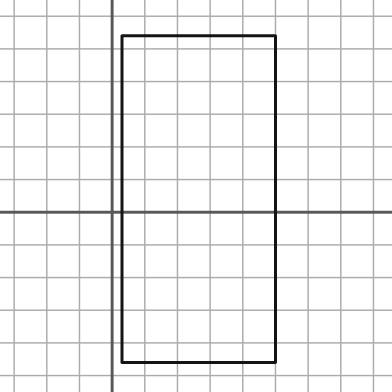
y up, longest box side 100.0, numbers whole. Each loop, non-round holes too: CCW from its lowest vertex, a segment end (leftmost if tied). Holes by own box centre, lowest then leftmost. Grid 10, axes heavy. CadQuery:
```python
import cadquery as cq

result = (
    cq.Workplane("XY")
    .moveTo(3.0, -46.0)
    .lineTo(50.0, -46.0)
    .lineTo(50.0, 54.0)
    .lineTo(3.0, 54.0)
    .close()
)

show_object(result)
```